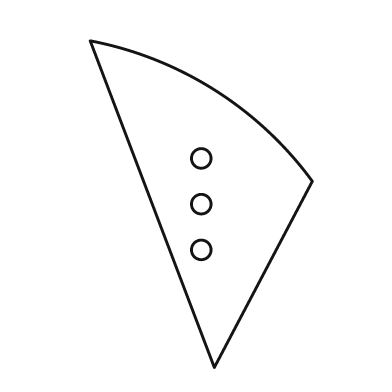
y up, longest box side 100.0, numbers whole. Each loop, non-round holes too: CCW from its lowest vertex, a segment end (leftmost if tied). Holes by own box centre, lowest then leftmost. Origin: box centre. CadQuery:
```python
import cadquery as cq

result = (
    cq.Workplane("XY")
    .moveTo(4.0, -50.0)
    .lineTo(34.0, 7.0)
    .threePointArc((4.0, 35.0), (-34.0, 50.0))
    .close()
    .moveTo(0.0, -14.0)
    .circle(3.0)
    .moveTo(0.0, 0.0)
    .circle(3.0)
    .moveTo(0.0, 14.0)
    .circle(3.0)
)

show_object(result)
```